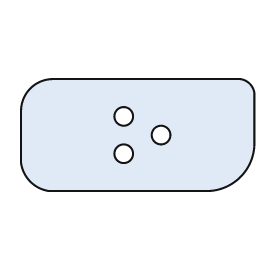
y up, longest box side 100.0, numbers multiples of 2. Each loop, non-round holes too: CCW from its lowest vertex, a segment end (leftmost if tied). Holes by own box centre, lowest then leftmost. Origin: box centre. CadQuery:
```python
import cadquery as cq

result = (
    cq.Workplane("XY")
    .moveTo(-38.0, -24.0)
    .lineTo(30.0, -24.0)
    .threePointArc((44.0, -18.0), (50.0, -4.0))
    .lineTo(50.0, 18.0)
    .threePointArc((48.0, 22.0), (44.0, 24.0))
    .lineTo(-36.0, 24.0)
    .threePointArc((-46.0, 20.0), (-50.0, 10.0))
    .lineTo(-50.0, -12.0)
    .threePointArc((-46.0, -20.0), (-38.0, -24.0))
    .close()
    .moveTo(-6.0, -8.0)
    .circle(4.0)
    .moveTo(10.0, 0.0)
    .circle(4.0)
    .moveTo(-6.0, 8.0)
    .circle(4.0)
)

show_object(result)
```